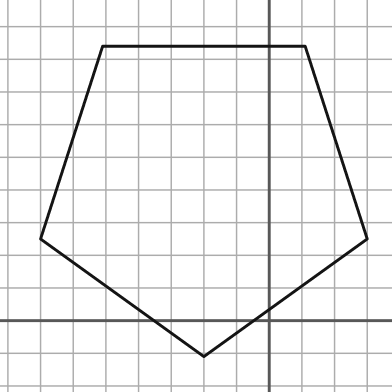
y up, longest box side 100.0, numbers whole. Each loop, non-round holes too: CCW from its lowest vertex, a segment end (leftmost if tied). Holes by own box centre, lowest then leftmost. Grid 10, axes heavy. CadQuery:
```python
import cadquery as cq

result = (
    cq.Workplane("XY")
    .moveTo(-20.0, -11.0)
    .lineTo(30.0, 25.0)
    .lineTo(11.0, 84.0)
    .lineTo(-51.0, 84.0)
    .lineTo(-70.0, 25.0)
    .close()
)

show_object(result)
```